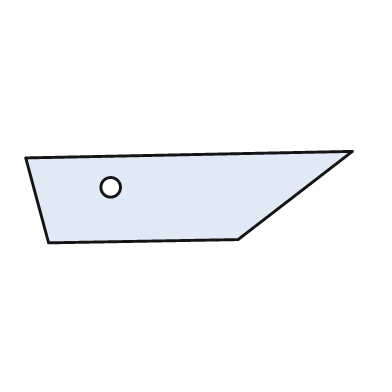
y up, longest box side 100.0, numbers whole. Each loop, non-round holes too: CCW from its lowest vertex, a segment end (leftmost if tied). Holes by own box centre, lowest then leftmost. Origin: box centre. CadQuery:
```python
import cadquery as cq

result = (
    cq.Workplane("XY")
    .moveTo(-43.0, -14.0)
    .lineTo(15.0, -13.0)
    .lineTo(50.0, 14.0)
    .lineTo(-50.0, 12.0)
    .close()
    .moveTo(-24.0, 3.0)
    .circle(3.0)
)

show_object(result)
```